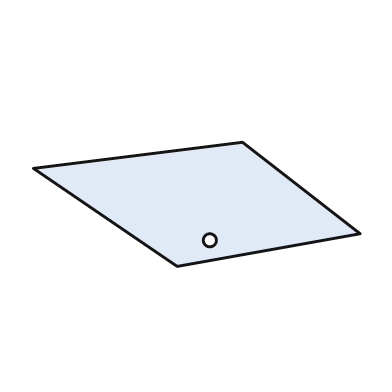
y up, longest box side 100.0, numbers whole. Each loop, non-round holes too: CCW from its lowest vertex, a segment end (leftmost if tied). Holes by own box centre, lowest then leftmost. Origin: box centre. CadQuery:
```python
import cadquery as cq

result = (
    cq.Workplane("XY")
    .moveTo(-6.0, -19.0)
    .lineTo(50.0, -9.0)
    .lineTo(14.0, 19.0)
    .lineTo(-50.0, 11.0)
    .close()
    .moveTo(4.0, -11.0)
    .circle(2.0)
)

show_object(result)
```